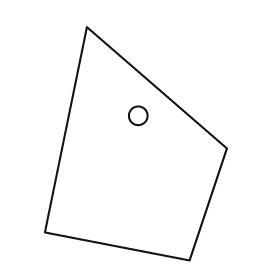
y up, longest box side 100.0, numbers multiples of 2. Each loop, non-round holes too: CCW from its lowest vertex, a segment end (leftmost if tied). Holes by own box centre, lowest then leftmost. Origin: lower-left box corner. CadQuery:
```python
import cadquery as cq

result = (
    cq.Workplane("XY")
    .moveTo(62.0, 0.0)
    .lineTo(78.0, 48.0)
    .lineTo(18.0, 100.0)
    .lineTo(0.0, 12.0)
    .close()
    .moveTo(40.0, 62.0)
    .circle(4.0)
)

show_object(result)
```